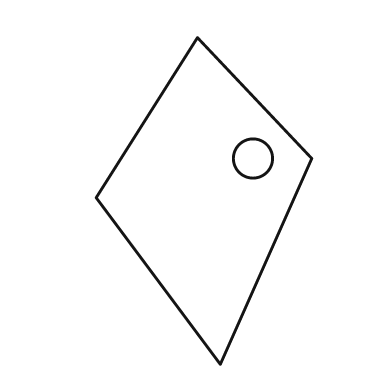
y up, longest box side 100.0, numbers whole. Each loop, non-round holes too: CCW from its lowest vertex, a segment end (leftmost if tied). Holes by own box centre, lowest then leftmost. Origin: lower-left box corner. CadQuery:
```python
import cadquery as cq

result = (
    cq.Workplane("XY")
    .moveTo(38.0, 0.0)
    .lineTo(66.0, 63.0)
    .lineTo(31.0, 100.0)
    .lineTo(0.0, 51.0)
    .close()
    .moveTo(48.0, 63.0)
    .circle(6.0)
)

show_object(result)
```